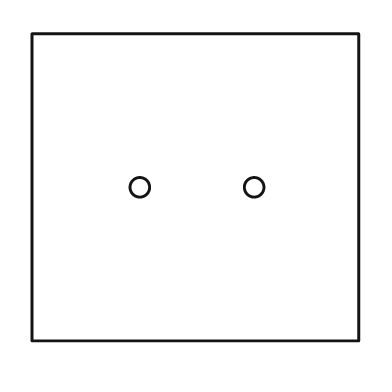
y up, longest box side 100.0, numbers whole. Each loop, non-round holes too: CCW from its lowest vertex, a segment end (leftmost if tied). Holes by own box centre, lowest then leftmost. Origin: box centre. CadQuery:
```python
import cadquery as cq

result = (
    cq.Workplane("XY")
    .moveTo(-50.0, -47.0)
    .lineTo(50.0, -47.0)
    .lineTo(50.0, 47.0)
    .lineTo(-50.0, 47.0)
    .close()
    .moveTo(-17.0, 0.0)
    .circle(3.0)
    .moveTo(18.0, 0.0)
    .circle(3.0)
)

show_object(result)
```